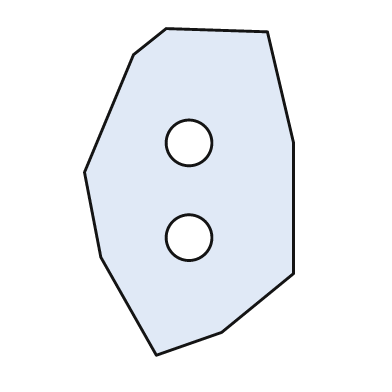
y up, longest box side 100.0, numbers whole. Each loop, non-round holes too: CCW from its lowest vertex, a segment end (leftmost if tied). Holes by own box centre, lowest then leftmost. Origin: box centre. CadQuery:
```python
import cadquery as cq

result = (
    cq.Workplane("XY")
    .moveTo(-10.0, -50.0)
    .lineTo(10.0, -43.0)
    .lineTo(32.0, -25.0)
    .lineTo(32.0, 15.0)
    .lineTo(24.0, 49.0)
    .lineTo(-7.0, 50.0)
    .lineTo(-17.0, 42.0)
    .lineTo(-32.0, 6.0)
    .lineTo(-27.0, -20.0)
    .close()
    .moveTo(0.0, -14.0)
    .circle(7.0)
    .moveTo(0.0, 15.0)
    .circle(7.0)
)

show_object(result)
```